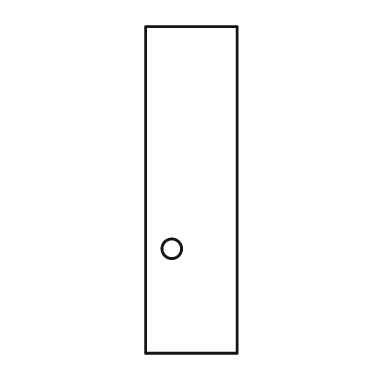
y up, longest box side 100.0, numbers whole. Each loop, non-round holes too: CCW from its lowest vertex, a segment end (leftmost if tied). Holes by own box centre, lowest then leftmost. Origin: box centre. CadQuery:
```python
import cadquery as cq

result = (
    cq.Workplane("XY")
    .moveTo(-14.0, -50.0)
    .lineTo(14.0, -50.0)
    .lineTo(14.0, 50.0)
    .lineTo(-14.0, 50.0)
    .close()
    .moveTo(-6.0, -18.0)
    .circle(3.0)
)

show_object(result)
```